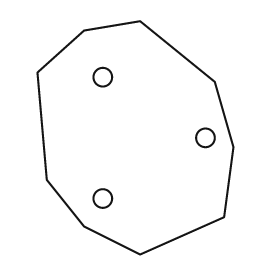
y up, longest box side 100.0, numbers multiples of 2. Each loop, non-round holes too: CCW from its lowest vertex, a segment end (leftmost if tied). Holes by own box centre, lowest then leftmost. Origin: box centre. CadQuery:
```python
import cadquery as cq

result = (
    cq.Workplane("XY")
    .moveTo(2.0, -50.0)
    .lineTo(38.0, -34.0)
    .lineTo(42.0, -4.0)
    .lineTo(34.0, 24.0)
    .lineTo(2.0, 50.0)
    .lineTo(-22.0, 46.0)
    .lineTo(-42.0, 28.0)
    .lineTo(-38.0, -18.0)
    .lineTo(-22.0, -38.0)
    .close()
    .moveTo(-14.0, -26.0)
    .circle(4.0)
    .moveTo(30.0, 0.0)
    .circle(4.0)
    .moveTo(-14.0, 26.0)
    .circle(4.0)
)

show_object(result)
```